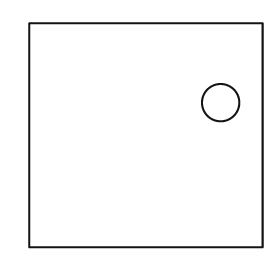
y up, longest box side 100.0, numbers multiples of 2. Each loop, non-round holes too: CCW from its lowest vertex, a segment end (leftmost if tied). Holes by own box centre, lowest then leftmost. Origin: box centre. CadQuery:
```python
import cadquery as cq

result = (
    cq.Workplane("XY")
    .moveTo(-50.0, -48.0)
    .lineTo(50.0, -48.0)
    .lineTo(50.0, 48.0)
    .lineTo(-50.0, 48.0)
    .close()
    .moveTo(32.0, 14.0)
    .circle(8.0)
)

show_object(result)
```